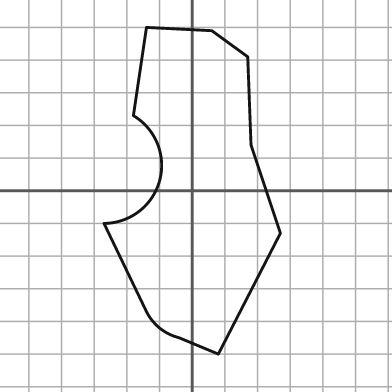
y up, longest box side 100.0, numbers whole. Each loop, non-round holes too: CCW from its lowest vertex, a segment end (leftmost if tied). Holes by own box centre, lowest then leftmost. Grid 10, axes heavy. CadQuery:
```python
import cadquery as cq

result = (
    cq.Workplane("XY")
    .moveTo(8.0, -50.0)
    .lineTo(27.0, -13.0)
    .lineTo(18.0, 14.0)
    .lineTo(17.0, 41.0)
    .lineTo(6.0, 49.0)
    .lineTo(-14.0, 50.0)
    .lineTo(-18.0, 23.0)
    .threePointArc((-10.0, 3.0), (-27.0, -10.0))
    .lineTo(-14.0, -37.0)
    .threePointArc((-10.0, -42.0), (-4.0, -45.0))
    .close()
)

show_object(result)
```